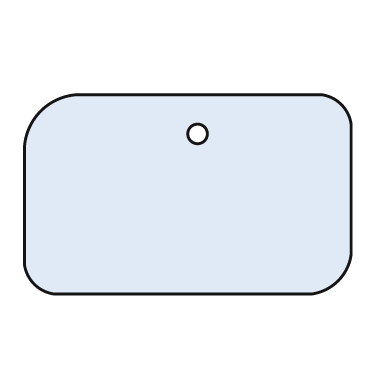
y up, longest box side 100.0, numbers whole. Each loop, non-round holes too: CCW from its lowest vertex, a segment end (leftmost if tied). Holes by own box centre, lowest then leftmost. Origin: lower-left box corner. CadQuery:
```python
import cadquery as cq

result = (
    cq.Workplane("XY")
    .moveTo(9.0, 0.0)
    .lineTo(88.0, 0.0)
    .threePointArc((96.0, 4.0), (100.0, 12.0))
    .lineTo(100.0, 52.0)
    .threePointArc((97.0, 58.0), (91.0, 61.0))
    .lineTo(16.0, 61.0)
    .threePointArc((5.0, 56.0), (0.0, 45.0))
    .lineTo(0.0, 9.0)
    .threePointArc((3.0, 3.0), (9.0, 0.0))
    .close()
    .moveTo(53.0, 49.0)
    .circle(3.0)
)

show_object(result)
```